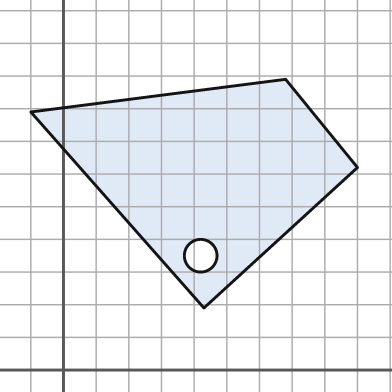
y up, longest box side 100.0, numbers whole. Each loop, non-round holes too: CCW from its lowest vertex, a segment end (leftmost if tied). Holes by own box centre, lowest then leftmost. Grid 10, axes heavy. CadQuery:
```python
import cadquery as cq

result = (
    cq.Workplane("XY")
    .moveTo(43.0, 19.0)
    .lineTo(90.0, 62.0)
    .lineTo(68.0, 89.0)
    .lineTo(-10.0, 79.0)
    .close()
    .moveTo(42.0, 35.0)
    .circle(5.0)
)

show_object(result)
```